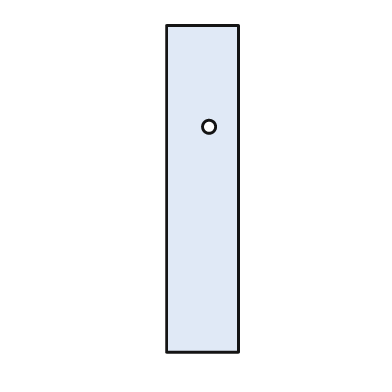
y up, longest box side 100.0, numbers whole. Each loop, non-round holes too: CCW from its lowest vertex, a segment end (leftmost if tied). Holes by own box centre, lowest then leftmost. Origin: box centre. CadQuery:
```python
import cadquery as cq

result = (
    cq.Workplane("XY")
    .moveTo(-11.0, -50.0)
    .lineTo(11.0, -50.0)
    .lineTo(11.0, 50.0)
    .lineTo(-11.0, 50.0)
    .close()
    .moveTo(2.0, 19.0)
    .circle(2.0)
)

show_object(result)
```